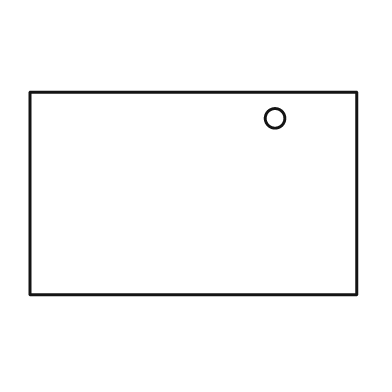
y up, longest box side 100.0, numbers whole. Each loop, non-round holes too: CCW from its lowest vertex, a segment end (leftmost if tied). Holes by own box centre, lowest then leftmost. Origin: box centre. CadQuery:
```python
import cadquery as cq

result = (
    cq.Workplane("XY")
    .moveTo(-50.0, -31.0)
    .lineTo(50.0, -31.0)
    .lineTo(50.0, 31.0)
    .lineTo(-50.0, 31.0)
    .close()
    .moveTo(25.0, 23.0)
    .circle(3.0)
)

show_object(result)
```